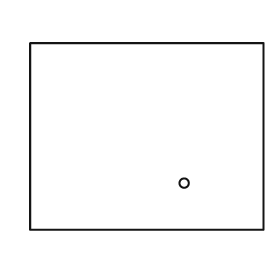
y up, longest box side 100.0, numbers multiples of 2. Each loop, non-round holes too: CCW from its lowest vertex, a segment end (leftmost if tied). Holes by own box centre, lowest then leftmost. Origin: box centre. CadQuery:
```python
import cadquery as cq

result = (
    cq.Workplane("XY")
    .moveTo(-50.0, -40.0)
    .lineTo(50.0, -40.0)
    .lineTo(50.0, 40.0)
    .lineTo(-50.0, 40.0)
    .close()
    .moveTo(16.0, -20.0)
    .circle(2.0)
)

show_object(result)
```